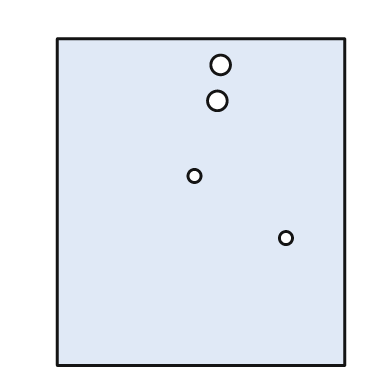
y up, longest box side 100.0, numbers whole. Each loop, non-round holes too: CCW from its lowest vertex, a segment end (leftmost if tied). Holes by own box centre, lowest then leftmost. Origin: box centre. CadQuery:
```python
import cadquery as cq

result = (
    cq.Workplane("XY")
    .moveTo(-44.0, -50.0)
    .lineTo(44.0, -50.0)
    .lineTo(44.0, 50.0)
    .lineTo(-44.0, 50.0)
    .close()
    .moveTo(26.0, -11.0)
    .circle(2.0)
    .moveTo(-2.0, 8.0)
    .circle(2.0)
    .moveTo(5.0, 31.0)
    .circle(3.0)
    .moveTo(6.0, 42.0)
    .circle(3.0)
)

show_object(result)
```